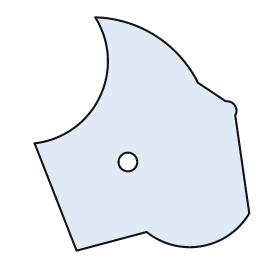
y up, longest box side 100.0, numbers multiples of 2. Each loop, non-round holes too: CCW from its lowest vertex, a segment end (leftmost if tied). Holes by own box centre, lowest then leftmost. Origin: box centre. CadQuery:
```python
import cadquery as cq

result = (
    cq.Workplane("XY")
    .moveTo(-28.0, -50.0)
    .lineTo(2.0, -42.0)
    .threePointArc((26.0, -48.0), (46.0, -34.0))
    .lineTo(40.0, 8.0)
    .threePointArc((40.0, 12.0), (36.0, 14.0))
    .lineTo(24.0, 22.0)
    .threePointArc((6.0, 42.0), (-20.0, 50.0))
    .threePointArc((-18.0, 16.0), (-46.0, -4.0))
    .close()
    .moveTo(-6.0, -12.0)
    .circle(4.0)
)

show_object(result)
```